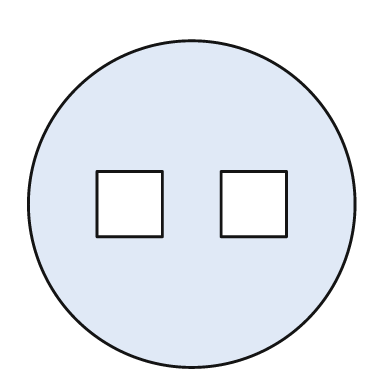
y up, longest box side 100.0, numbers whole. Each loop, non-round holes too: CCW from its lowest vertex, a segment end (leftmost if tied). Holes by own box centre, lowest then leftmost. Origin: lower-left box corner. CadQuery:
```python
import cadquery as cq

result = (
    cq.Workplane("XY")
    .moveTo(50.0, 50.0)
    .circle(50.0)
    .moveTo(21.0, 40.0)
    .lineTo(41.0, 40.0)
    .lineTo(41.0, 60.0)
    .lineTo(21.0, 60.0)
    .close()
    .moveTo(59.0, 40.0)
    .lineTo(79.0, 40.0)
    .lineTo(79.0, 60.0)
    .lineTo(59.0, 60.0)
    .close()
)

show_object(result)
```